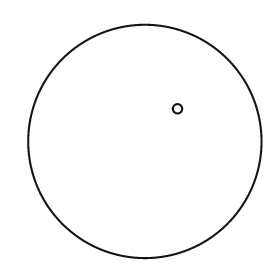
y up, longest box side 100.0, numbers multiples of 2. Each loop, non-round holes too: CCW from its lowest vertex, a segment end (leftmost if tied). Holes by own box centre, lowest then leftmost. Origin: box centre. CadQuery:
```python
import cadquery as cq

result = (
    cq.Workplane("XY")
    .moveTo(0.0, 0.0)
    .circle(50.0)
    .moveTo(14.0, 14.0)
    .circle(2.0)
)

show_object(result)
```